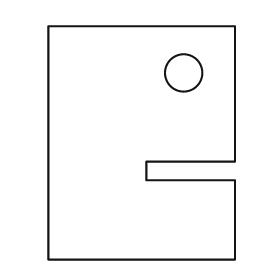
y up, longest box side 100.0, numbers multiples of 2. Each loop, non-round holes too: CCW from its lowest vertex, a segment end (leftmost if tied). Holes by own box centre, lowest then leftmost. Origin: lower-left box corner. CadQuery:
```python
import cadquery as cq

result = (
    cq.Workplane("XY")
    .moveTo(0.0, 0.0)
    .lineTo(80.0, 0.0)
    .lineTo(80.0, 34.0)
    .lineTo(42.0, 34.0)
    .lineTo(42.0, 42.0)
    .lineTo(80.0, 42.0)
    .lineTo(80.0, 100.0)
    .lineTo(0.0, 100.0)
    .close()
    .moveTo(58.0, 80.0)
    .circle(8.0)
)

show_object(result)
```